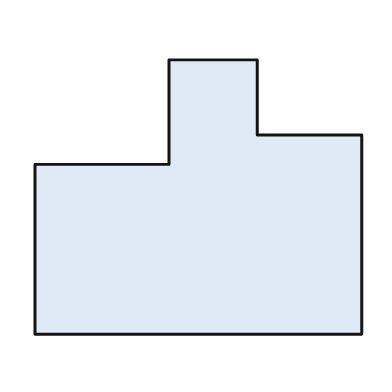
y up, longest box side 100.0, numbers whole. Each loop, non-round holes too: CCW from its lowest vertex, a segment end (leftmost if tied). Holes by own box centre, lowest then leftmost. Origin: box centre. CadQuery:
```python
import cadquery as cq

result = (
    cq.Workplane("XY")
    .moveTo(-50.0, -42.0)
    .lineTo(50.0, -42.0)
    .lineTo(50.0, 19.0)
    .lineTo(18.0, 19.0)
    .lineTo(18.0, 42.0)
    .lineTo(-9.0, 42.0)
    .lineTo(-9.0, 10.0)
    .lineTo(-50.0, 10.0)
    .close()
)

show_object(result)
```